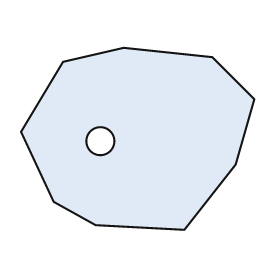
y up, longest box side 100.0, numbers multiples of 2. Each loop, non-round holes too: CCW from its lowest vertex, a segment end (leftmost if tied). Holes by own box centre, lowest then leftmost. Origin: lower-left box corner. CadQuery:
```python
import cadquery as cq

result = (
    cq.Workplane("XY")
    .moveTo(70.0, 0.0)
    .lineTo(92.0, 28.0)
    .lineTo(100.0, 56.0)
    .lineTo(82.0, 74.0)
    .lineTo(44.0, 78.0)
    .lineTo(18.0, 72.0)
    .lineTo(0.0, 42.0)
    .lineTo(14.0, 12.0)
    .lineTo(32.0, 2.0)
    .close()
    .moveTo(34.0, 38.0)
    .circle(6.0)
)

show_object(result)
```